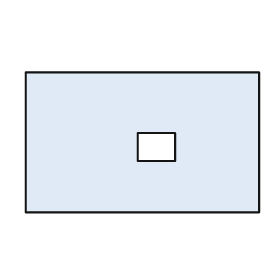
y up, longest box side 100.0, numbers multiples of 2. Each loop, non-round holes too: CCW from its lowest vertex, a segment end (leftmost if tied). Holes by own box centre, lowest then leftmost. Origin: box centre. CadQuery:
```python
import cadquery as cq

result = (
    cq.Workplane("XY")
    .moveTo(-50.0, -30.0)
    .lineTo(50.0, -30.0)
    .lineTo(50.0, 30.0)
    .lineTo(-50.0, 30.0)
    .close()
    .moveTo(-2.0, -8.0)
    .lineTo(14.0, -8.0)
    .lineTo(14.0, 4.0)
    .lineTo(-2.0, 4.0)
    .close()
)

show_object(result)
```